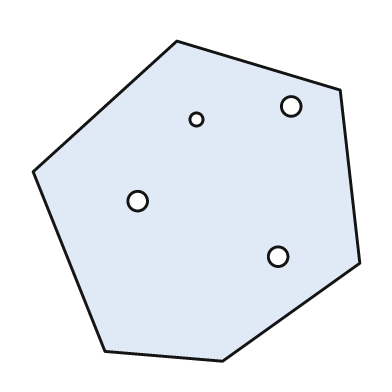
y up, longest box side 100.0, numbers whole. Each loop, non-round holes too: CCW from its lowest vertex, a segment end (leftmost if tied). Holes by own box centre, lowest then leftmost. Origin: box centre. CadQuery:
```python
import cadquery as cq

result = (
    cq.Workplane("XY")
    .moveTo(8.0, -49.0)
    .lineTo(50.0, -19.0)
    .lineTo(44.0, 34.0)
    .lineTo(-6.0, 49.0)
    .lineTo(-50.0, 9.0)
    .lineTo(-28.0, -46.0)
    .close()
    .moveTo(25.0, -17.0)
    .circle(3.0)
    .moveTo(-18.0, 0.0)
    .circle(3.0)
    .moveTo(0.0, 25.0)
    .circle(2.0)
    .moveTo(29.0, 29.0)
    .circle(3.0)
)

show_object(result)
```